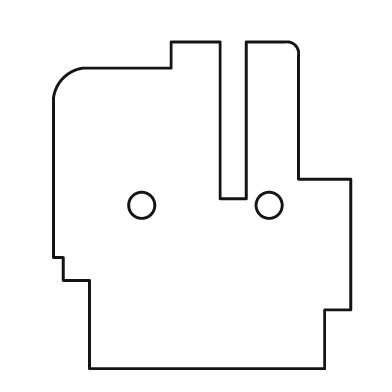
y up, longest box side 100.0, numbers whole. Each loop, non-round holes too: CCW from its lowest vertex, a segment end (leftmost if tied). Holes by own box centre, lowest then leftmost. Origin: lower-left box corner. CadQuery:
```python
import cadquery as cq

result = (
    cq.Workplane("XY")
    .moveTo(11.0, 0.0)
    .lineTo(83.0, 0.0)
    .lineTo(83.0, 18.0)
    .lineTo(91.0, 18.0)
    .lineTo(91.0, 58.0)
    .lineTo(75.0, 58.0)
    .lineTo(75.0, 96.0)
    .threePointArc((74.0, 99.0), (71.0, 100.0))
    .lineTo(59.0, 100.0)
    .lineTo(59.0, 52.0)
    .lineTo(51.0, 52.0)
    .lineTo(51.0, 100.0)
    .lineTo(36.0, 100.0)
    .lineTo(36.0, 92.0)
    .lineTo(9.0, 92.0)
    .threePointArc((3.0, 89.0), (0.0, 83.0))
    .lineTo(0.0, 34.0)
    .lineTo(3.0, 34.0)
    .lineTo(3.0, 27.0)
    .lineTo(11.0, 27.0)
    .close()
    .moveTo(27.0, 50.0)
    .circle(4.0)
    .moveTo(66.0, 50.0)
    .circle(4.0)
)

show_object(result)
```